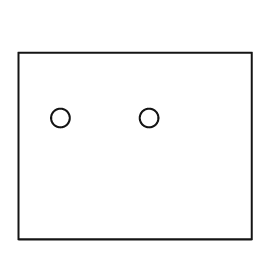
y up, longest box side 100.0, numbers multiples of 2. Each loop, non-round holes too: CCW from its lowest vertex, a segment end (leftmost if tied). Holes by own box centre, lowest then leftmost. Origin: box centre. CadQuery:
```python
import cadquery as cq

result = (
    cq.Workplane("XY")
    .moveTo(-50.0, -40.0)
    .lineTo(50.0, -40.0)
    .lineTo(50.0, 40.0)
    .lineTo(-50.0, 40.0)
    .close()
    .moveTo(-32.0, 12.0)
    .circle(4.0)
    .moveTo(6.0, 12.0)
    .circle(4.0)
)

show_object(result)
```